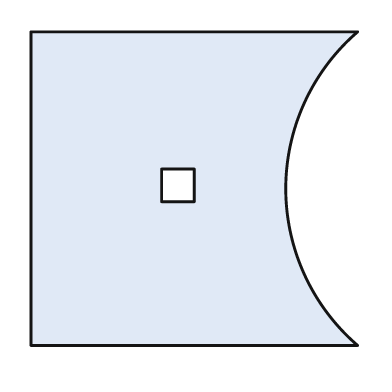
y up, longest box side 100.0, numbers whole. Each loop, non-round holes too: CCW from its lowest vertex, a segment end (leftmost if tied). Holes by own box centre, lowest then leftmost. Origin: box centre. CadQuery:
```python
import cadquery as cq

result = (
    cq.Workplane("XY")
    .moveTo(-50.0, -48.0)
    .lineTo(50.0, -48.0)
    .threePointArc((28.0, 0.0), (50.0, 48.0))
    .lineTo(-50.0, 48.0)
    .close()
    .moveTo(-10.0, -4.0)
    .lineTo(0.0, -4.0)
    .lineTo(0.0, 6.0)
    .lineTo(-10.0, 6.0)
    .close()
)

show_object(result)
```